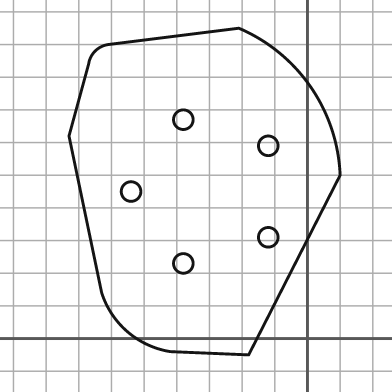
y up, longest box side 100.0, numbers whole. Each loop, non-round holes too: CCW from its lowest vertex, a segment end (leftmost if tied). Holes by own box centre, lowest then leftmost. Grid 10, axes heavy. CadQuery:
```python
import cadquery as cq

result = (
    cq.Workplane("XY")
    .moveTo(-18.0, -5.0)
    .lineTo(10.0, 50.0)
    .threePointArc((1.0, 77.0), (-21.0, 95.0))
    .lineTo(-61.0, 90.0)
    .threePointArc((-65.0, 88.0), (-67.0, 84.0))
    .lineTo(-73.0, 62.0)
    .lineTo(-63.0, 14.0)
    .threePointArc((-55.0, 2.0), (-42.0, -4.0))
    .close()
    .moveTo(-38.0, 23.0)
    .circle(3.0)
    .moveTo(-12.0, 31.0)
    .circle(3.0)
    .moveTo(-54.0, 45.0)
    .circle(3.0)
    .moveTo(-12.0, 59.0)
    .circle(3.0)
    .moveTo(-38.0, 67.0)
    .circle(3.0)
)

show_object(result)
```